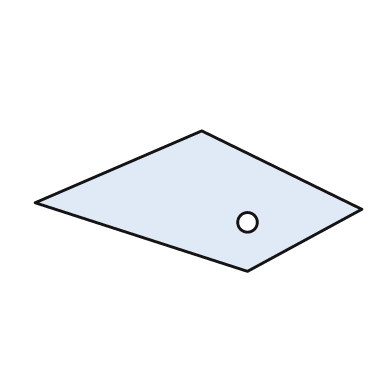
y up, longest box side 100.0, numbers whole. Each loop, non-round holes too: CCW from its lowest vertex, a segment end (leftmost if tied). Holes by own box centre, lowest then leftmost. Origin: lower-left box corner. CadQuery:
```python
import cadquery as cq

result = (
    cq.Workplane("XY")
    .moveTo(65.0, 0.0)
    .lineTo(100.0, 19.0)
    .lineTo(51.0, 43.0)
    .lineTo(0.0, 21.0)
    .close()
    .moveTo(65.0, 15.0)
    .circle(3.0)
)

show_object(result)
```